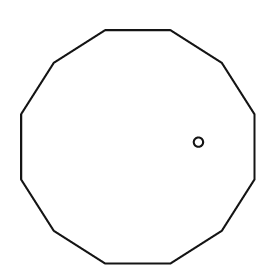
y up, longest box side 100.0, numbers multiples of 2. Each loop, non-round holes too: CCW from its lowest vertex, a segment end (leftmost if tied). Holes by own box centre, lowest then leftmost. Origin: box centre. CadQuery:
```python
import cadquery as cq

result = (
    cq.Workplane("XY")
    .moveTo(-14.0, -50.0)
    .lineTo(14.0, -50.0)
    .lineTo(36.0, -36.0)
    .lineTo(50.0, -14.0)
    .lineTo(50.0, 14.0)
    .lineTo(36.0, 36.0)
    .lineTo(14.0, 50.0)
    .lineTo(-14.0, 50.0)
    .lineTo(-36.0, 36.0)
    .lineTo(-50.0, 14.0)
    .lineTo(-50.0, -14.0)
    .lineTo(-36.0, -36.0)
    .close()
    .moveTo(26.0, 2.0)
    .circle(2.0)
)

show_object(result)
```